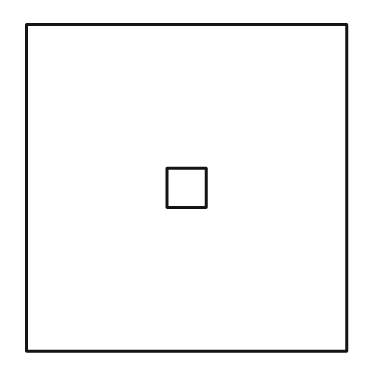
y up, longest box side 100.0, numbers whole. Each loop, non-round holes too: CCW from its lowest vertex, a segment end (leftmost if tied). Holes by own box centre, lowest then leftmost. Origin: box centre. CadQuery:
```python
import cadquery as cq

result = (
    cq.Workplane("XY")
    .moveTo(-49.0, -50.0)
    .lineTo(49.0, -50.0)
    .lineTo(49.0, 50.0)
    .lineTo(-49.0, 50.0)
    .close()
    .moveTo(-6.0, -6.0)
    .lineTo(6.0, -6.0)
    .lineTo(6.0, 6.0)
    .lineTo(-6.0, 6.0)
    .close()
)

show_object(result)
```